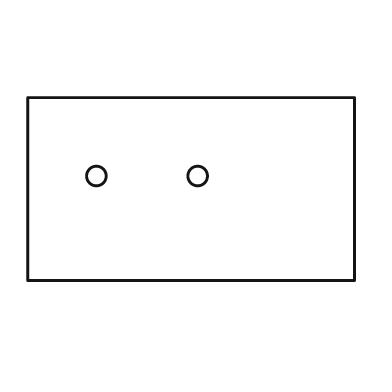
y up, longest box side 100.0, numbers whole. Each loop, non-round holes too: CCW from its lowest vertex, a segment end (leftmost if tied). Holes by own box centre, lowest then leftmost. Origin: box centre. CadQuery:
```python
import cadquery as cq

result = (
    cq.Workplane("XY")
    .moveTo(-50.0, -28.0)
    .lineTo(50.0, -28.0)
    .lineTo(50.0, 28.0)
    .lineTo(-50.0, 28.0)
    .close()
    .moveTo(-29.0, 4.0)
    .circle(3.0)
    .moveTo(2.0, 4.0)
    .circle(3.0)
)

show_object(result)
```